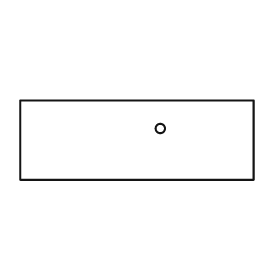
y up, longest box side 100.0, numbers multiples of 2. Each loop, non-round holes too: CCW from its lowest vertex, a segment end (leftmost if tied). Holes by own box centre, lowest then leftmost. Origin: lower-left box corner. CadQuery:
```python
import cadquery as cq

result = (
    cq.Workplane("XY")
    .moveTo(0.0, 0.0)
    .lineTo(100.0, 0.0)
    .lineTo(100.0, 34.0)
    .lineTo(0.0, 34.0)
    .close()
    .moveTo(60.0, 22.0)
    .circle(2.0)
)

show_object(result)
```